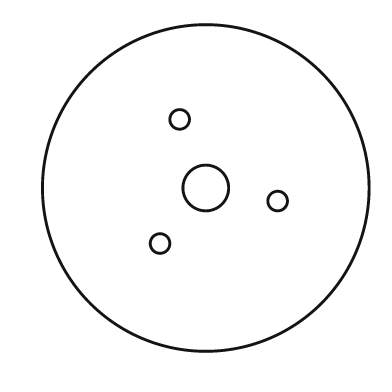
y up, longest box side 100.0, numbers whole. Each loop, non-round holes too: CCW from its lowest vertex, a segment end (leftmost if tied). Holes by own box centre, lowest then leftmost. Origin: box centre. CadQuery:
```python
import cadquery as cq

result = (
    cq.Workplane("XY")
    .moveTo(0.0, 0.0)
    .circle(50.0)
    .moveTo(-14.0, -17.0)
    .circle(3.0)
    .moveTo(22.0, -4.0)
    .circle(3.0)
    .moveTo(0.0, 0.0)
    .circle(7.0)
    .moveTo(-8.0, 21.0)
    .circle(3.0)
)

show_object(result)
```